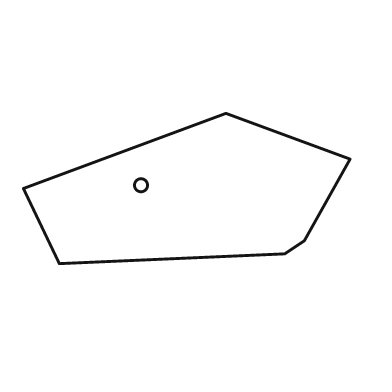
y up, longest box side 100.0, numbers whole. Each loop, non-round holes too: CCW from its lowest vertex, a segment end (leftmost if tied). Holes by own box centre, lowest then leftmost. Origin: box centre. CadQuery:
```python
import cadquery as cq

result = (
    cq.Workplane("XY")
    .moveTo(-39.0, -23.0)
    .lineTo(30.0, -20.0)
    .lineTo(36.0, -16.0)
    .lineTo(50.0, 9.0)
    .lineTo(12.0, 23.0)
    .lineTo(-50.0, 0.0)
    .close()
    .moveTo(-14.0, 1.0)
    .circle(2.0)
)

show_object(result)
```